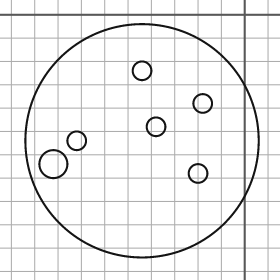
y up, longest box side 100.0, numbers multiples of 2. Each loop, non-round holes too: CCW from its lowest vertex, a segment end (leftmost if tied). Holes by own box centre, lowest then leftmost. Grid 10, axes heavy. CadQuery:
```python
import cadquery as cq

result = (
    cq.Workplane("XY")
    .moveTo(-44.0, -54.0)
    .circle(50.0)
    .moveTo(-20.0, -68.0)
    .circle(4.0)
    .moveTo(-82.0, -64.0)
    .circle(6.0)
    .moveTo(-72.0, -54.0)
    .circle(4.0)
    .moveTo(-38.0, -48.0)
    .circle(4.0)
    .moveTo(-18.0, -38.0)
    .circle(4.0)
    .moveTo(-44.0, -24.0)
    .circle(4.0)
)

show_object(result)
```